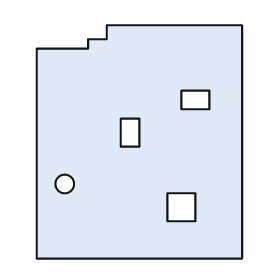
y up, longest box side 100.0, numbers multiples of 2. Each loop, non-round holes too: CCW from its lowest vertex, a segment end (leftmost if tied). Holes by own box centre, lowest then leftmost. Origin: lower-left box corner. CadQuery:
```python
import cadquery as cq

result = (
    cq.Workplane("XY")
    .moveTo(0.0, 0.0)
    .lineTo(88.0, 0.0)
    .lineTo(88.0, 100.0)
    .lineTo(30.0, 100.0)
    .lineTo(30.0, 94.0)
    .lineTo(22.0, 94.0)
    .lineTo(22.0, 90.0)
    .lineTo(0.0, 90.0)
    .close()
    .moveTo(56.0, 16.0)
    .lineTo(68.0, 16.0)
    .lineTo(68.0, 28.0)
    .lineTo(56.0, 28.0)
    .close()
    .moveTo(12.0, 32.0)
    .circle(4.0)
    .moveTo(36.0, 48.0)
    .lineTo(44.0, 48.0)
    .lineTo(44.0, 60.0)
    .lineTo(36.0, 60.0)
    .close()
    .moveTo(62.0, 64.0)
    .lineTo(74.0, 64.0)
    .lineTo(74.0, 72.0)
    .lineTo(62.0, 72.0)
    .close()
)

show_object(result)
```